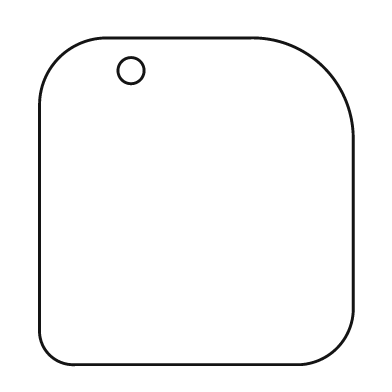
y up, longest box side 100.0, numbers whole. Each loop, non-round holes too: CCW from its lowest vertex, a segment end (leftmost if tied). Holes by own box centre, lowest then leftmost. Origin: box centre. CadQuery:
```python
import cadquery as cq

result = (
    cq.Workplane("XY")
    .moveTo(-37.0, -50.0)
    .lineTo(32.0, -50.0)
    .threePointArc((43.0, -45.0), (48.0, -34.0))
    .lineTo(48.0, 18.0)
    .threePointArc((39.0, 41.0), (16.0, 50.0))
    .lineTo(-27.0, 50.0)
    .threePointArc((-42.0, 44.0), (-48.0, 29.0))
    .lineTo(-48.0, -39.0)
    .threePointArc((-45.0, -47.0), (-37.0, -50.0))
    .close()
    .moveTo(-20.0, 40.0)
    .circle(4.0)
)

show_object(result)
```